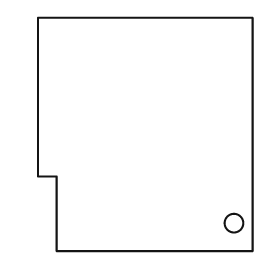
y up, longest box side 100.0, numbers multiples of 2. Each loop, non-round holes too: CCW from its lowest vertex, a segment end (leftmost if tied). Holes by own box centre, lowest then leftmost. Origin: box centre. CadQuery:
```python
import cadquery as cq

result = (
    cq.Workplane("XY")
    .moveTo(-38.0, -50.0)
    .lineTo(46.0, -50.0)
    .lineTo(46.0, 50.0)
    .lineTo(-46.0, 50.0)
    .lineTo(-46.0, -18.0)
    .lineTo(-38.0, -18.0)
    .close()
    .moveTo(38.0, -38.0)
    .circle(4.0)
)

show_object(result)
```